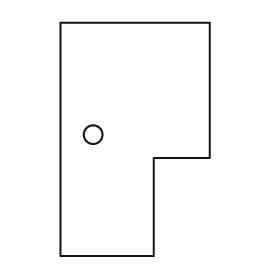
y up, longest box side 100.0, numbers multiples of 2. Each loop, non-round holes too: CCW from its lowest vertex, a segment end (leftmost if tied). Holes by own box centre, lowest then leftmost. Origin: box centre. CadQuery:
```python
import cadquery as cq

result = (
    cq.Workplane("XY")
    .moveTo(-32.0, -50.0)
    .lineTo(8.0, -50.0)
    .lineTo(8.0, -8.0)
    .lineTo(32.0, -8.0)
    .lineTo(32.0, 50.0)
    .lineTo(-32.0, 50.0)
    .close()
    .moveTo(-18.0, 2.0)
    .circle(4.0)
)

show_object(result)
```